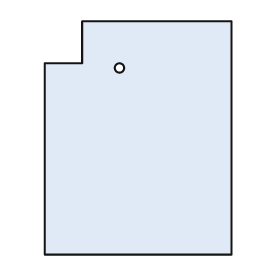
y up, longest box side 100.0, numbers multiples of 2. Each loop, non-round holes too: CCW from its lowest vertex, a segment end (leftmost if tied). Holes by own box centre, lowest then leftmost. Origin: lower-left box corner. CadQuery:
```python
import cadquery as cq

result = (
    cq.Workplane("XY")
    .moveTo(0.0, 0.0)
    .lineTo(80.0, 0.0)
    .lineTo(80.0, 100.0)
    .lineTo(16.0, 100.0)
    .lineTo(16.0, 82.0)
    .lineTo(0.0, 82.0)
    .close()
    .moveTo(32.0, 80.0)
    .circle(2.0)
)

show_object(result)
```